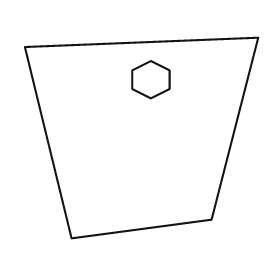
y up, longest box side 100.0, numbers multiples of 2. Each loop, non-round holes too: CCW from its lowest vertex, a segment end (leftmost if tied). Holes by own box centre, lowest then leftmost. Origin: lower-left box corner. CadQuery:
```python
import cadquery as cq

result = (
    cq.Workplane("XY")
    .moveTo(20.0, 0.0)
    .lineTo(80.0, 8.0)
    .lineTo(100.0, 86.0)
    .lineTo(0.0, 82.0)
    .close()
    .moveTo(54.0, 60.0)
    .lineTo(62.0, 64.0)
    .lineTo(62.0, 72.0)
    .lineTo(54.0, 76.0)
    .lineTo(46.0, 72.0)
    .lineTo(46.0, 64.0)
    .close()
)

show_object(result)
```